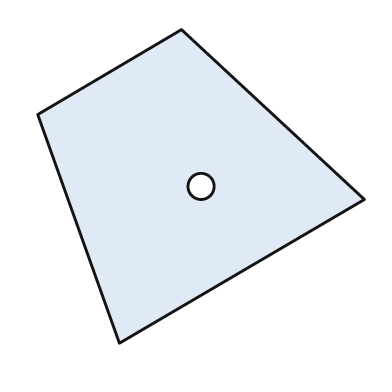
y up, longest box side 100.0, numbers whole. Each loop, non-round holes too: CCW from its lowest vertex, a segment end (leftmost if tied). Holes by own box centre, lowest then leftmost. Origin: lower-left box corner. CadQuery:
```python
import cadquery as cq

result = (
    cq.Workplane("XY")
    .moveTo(25.0, 0.0)
    .lineTo(100.0, 44.0)
    .lineTo(44.0, 96.0)
    .lineTo(0.0, 70.0)
    .close()
    .moveTo(50.0, 48.0)
    .circle(4.0)
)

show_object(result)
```